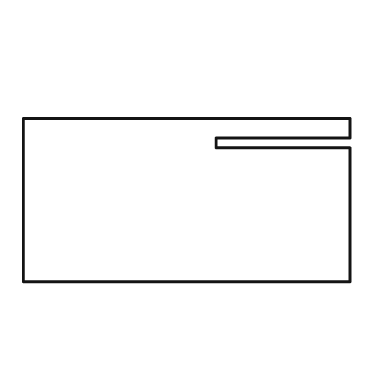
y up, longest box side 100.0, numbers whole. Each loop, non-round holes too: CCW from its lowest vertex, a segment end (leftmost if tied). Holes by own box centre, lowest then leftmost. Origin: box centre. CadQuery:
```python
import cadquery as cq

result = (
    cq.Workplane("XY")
    .moveTo(-50.0, -25.0)
    .lineTo(50.0, -25.0)
    .lineTo(50.0, 16.0)
    .lineTo(9.0, 16.0)
    .lineTo(9.0, 19.0)
    .lineTo(50.0, 19.0)
    .lineTo(50.0, 25.0)
    .lineTo(-50.0, 25.0)
    .close()
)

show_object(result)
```